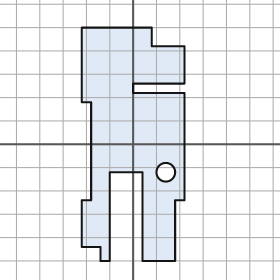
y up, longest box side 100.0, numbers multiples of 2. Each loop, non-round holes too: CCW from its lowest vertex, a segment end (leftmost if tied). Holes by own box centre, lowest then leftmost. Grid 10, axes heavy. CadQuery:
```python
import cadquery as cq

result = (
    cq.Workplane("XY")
    .moveTo(-14.0, -50.0)
    .lineTo(-10.0, -50.0)
    .lineTo(-10.0, -12.0)
    .lineTo(4.0, -12.0)
    .lineTo(4.0, -50.0)
    .lineTo(18.0, -50.0)
    .lineTo(18.0, -24.0)
    .lineTo(22.0, -24.0)
    .lineTo(22.0, 22.0)
    .lineTo(0.0, 22.0)
    .lineTo(0.0, 26.0)
    .lineTo(22.0, 26.0)
    .lineTo(22.0, 42.0)
    .lineTo(8.0, 42.0)
    .lineTo(8.0, 50.0)
    .lineTo(-22.0, 50.0)
    .lineTo(-22.0, 18.0)
    .lineTo(-18.0, 18.0)
    .lineTo(-18.0, -24.0)
    .lineTo(-22.0, -24.0)
    .lineTo(-22.0, -44.0)
    .lineTo(-14.0, -44.0)
    .close()
    .moveTo(14.0, -12.0)
    .circle(4.0)
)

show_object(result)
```